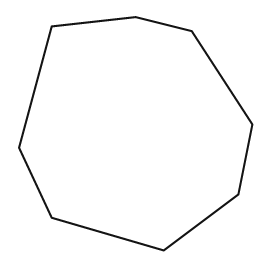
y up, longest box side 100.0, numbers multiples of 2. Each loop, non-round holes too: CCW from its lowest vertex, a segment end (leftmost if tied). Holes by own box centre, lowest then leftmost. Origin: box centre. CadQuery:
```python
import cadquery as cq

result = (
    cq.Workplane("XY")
    .moveTo(12.0, -50.0)
    .lineTo(44.0, -26.0)
    .lineTo(50.0, 4.0)
    .lineTo(24.0, 44.0)
    .lineTo(0.0, 50.0)
    .lineTo(-36.0, 46.0)
    .lineTo(-50.0, -6.0)
    .lineTo(-36.0, -36.0)
    .close()
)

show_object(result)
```